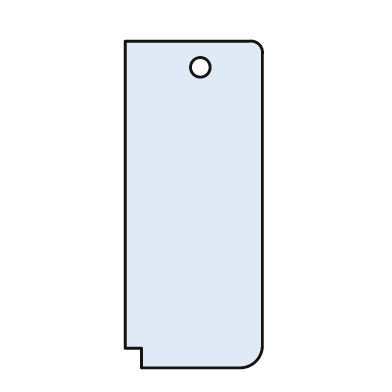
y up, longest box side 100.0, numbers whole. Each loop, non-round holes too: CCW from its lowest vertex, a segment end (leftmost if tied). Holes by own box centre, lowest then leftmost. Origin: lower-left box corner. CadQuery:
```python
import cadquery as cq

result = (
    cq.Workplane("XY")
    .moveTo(5.0, 0.0)
    .lineTo(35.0, 0.0)
    .threePointArc((40.0, 2.0), (42.0, 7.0))
    .lineTo(42.0, 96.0)
    .threePointArc((41.0, 99.0), (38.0, 100.0))
    .lineTo(0.0, 100.0)
    .lineTo(0.0, 6.0)
    .lineTo(5.0, 6.0)
    .close()
    .moveTo(23.0, 92.0)
    .circle(3.0)
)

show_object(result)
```